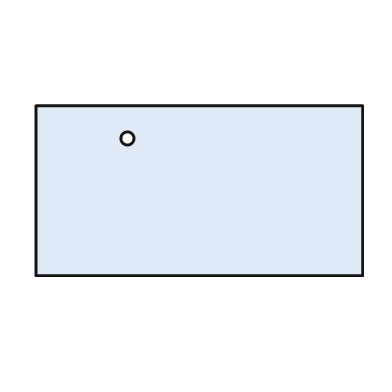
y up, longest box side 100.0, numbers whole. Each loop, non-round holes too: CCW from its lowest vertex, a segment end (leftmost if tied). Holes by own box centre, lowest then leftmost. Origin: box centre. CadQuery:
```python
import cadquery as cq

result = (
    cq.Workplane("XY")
    .moveTo(-50.0, -26.0)
    .lineTo(50.0, -26.0)
    .lineTo(50.0, 26.0)
    .lineTo(-50.0, 26.0)
    .close()
    .moveTo(-22.0, 16.0)
    .circle(2.0)
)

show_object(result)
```